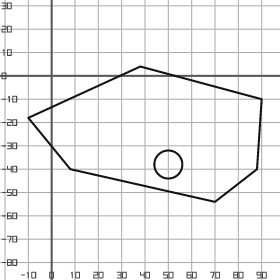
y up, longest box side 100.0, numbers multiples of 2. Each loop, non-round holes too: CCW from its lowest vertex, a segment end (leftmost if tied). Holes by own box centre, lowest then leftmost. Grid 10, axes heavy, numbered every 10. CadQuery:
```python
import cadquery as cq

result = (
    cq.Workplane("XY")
    .moveTo(70.0, -54.0)
    .lineTo(88.0, -40.0)
    .lineTo(90.0, -10.0)
    .lineTo(38.0, 4.0)
    .lineTo(-10.0, -18.0)
    .lineTo(8.0, -40.0)
    .close()
    .moveTo(50.0, -38.0)
    .circle(6.0)
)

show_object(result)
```